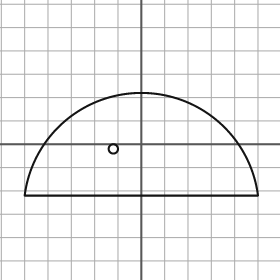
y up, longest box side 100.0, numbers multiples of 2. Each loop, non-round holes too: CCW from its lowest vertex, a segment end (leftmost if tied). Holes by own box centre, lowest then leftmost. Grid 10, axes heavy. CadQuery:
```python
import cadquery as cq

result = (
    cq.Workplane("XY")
    .moveTo(-50.0, -22.0)
    .lineTo(50.0, -22.0)
    .threePointArc((0.0, 22.0), (-50.0, -22.0))
    .close()
    .moveTo(-12.0, -2.0)
    .circle(2.0)
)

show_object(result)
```